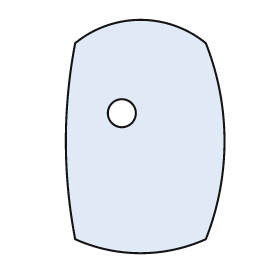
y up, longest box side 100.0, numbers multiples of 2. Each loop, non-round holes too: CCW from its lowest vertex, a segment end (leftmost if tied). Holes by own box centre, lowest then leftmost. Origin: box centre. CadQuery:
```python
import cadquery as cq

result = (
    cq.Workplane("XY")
    .moveTo(-30.0, -44.0)
    .threePointArc((-2.0, -50.0), (26.0, -44.0))
    .threePointArc((34.0, -2.0), (26.0, 40.0))
    .threePointArc((-2.0, 50.0), (-30.0, 40.0))
    .threePointArc((-34.0, -2.0), (-30.0, -44.0))
    .close()
    .moveTo(-10.0, 10.0)
    .circle(6.0)
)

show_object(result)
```